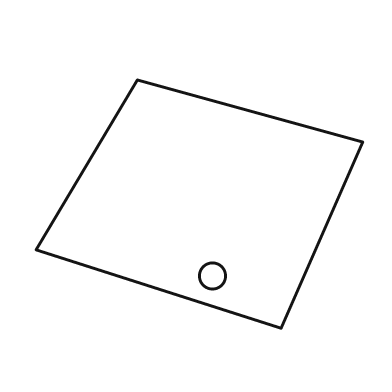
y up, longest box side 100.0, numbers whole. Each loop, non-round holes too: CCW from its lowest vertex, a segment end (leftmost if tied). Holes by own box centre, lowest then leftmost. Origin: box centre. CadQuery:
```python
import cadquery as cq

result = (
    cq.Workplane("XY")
    .moveTo(25.0, -38.0)
    .lineTo(50.0, 19.0)
    .lineTo(-19.0, 38.0)
    .lineTo(-50.0, -14.0)
    .close()
    .moveTo(4.0, -22.0)
    .circle(4.0)
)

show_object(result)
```